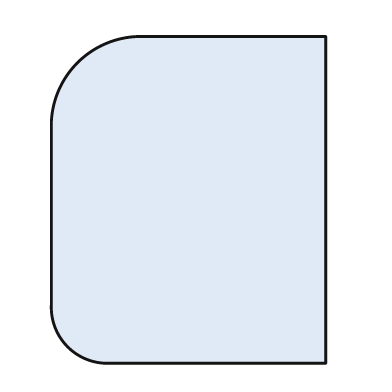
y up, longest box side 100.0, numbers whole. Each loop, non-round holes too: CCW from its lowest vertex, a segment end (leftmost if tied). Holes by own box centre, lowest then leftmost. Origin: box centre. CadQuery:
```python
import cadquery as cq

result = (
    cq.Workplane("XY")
    .moveTo(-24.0, -50.0)
    .lineTo(42.0, -50.0)
    .lineTo(42.0, 50.0)
    .lineTo(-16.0, 50.0)
    .threePointArc((-34.0, 42.0), (-42.0, 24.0))
    .lineTo(-42.0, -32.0)
    .threePointArc((-37.0, -45.0), (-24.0, -50.0))
    .close()
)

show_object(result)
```